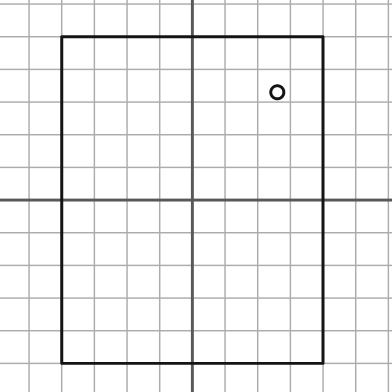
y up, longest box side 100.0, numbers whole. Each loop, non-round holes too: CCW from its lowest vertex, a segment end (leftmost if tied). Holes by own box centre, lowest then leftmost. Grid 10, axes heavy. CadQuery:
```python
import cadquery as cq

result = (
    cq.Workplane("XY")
    .moveTo(-40.0, -50.0)
    .lineTo(40.0, -50.0)
    .lineTo(40.0, 50.0)
    .lineTo(-40.0, 50.0)
    .close()
    .moveTo(26.0, 33.0)
    .circle(2.0)
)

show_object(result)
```